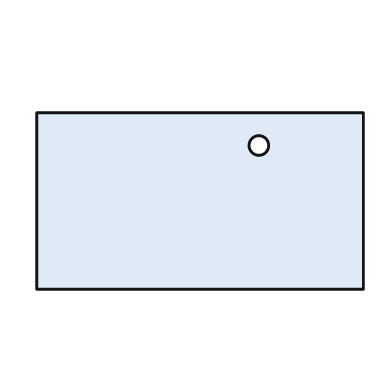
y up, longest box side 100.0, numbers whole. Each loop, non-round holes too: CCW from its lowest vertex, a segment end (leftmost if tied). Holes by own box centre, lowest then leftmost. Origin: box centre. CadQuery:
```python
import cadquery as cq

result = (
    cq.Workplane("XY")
    .moveTo(-50.0, -27.0)
    .lineTo(50.0, -27.0)
    .lineTo(50.0, 27.0)
    .lineTo(-50.0, 27.0)
    .close()
    .moveTo(18.0, 17.0)
    .circle(3.0)
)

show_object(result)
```